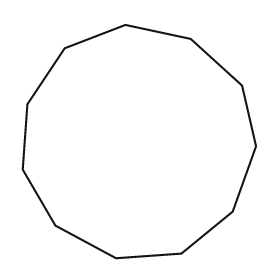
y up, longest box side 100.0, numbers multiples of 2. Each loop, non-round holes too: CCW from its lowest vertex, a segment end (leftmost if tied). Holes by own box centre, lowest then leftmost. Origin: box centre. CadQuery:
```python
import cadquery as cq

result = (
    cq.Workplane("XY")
    .moveTo(-10.0, -50.0)
    .lineTo(18.0, -48.0)
    .lineTo(40.0, -30.0)
    .lineTo(50.0, -2.0)
    .lineTo(44.0, 24.0)
    .lineTo(22.0, 44.0)
    .lineTo(-6.0, 50.0)
    .lineTo(-32.0, 40.0)
    .lineTo(-48.0, 16.0)
    .lineTo(-50.0, -12.0)
    .lineTo(-36.0, -36.0)
    .close()
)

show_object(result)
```